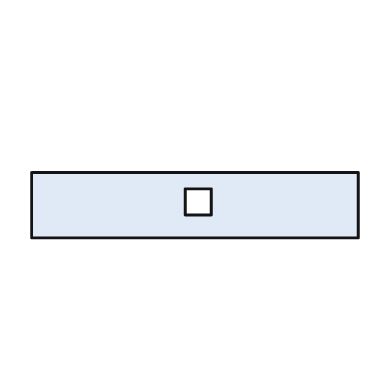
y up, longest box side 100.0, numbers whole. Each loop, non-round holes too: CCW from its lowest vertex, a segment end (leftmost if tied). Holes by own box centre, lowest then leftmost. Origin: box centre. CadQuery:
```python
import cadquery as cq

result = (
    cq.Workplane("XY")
    .moveTo(-50.0, -10.0)
    .lineTo(50.0, -10.0)
    .lineTo(50.0, 10.0)
    .lineTo(-50.0, 10.0)
    .close()
    .moveTo(-3.0, -3.0)
    .lineTo(5.0, -3.0)
    .lineTo(5.0, 5.0)
    .lineTo(-3.0, 5.0)
    .close()
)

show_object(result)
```